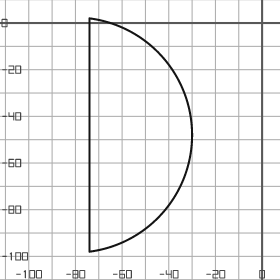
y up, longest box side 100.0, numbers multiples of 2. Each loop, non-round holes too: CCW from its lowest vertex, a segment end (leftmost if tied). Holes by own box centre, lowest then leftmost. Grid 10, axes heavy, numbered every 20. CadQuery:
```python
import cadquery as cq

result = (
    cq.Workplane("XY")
    .moveTo(-74.0, -98.0)
    .threePointArc((-30.0, -48.0), (-74.0, 2.0))
    .close()
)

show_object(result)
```